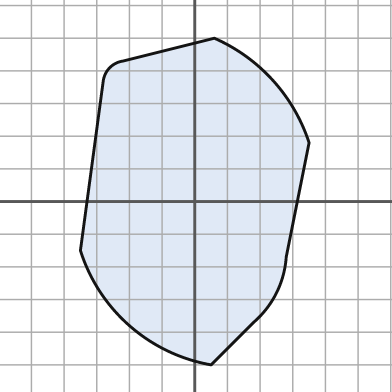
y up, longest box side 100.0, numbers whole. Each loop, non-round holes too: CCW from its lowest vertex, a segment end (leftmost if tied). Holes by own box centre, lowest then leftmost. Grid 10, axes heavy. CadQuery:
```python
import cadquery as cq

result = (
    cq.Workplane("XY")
    .moveTo(5.0, -50.0)
    .lineTo(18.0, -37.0)
    .threePointArc((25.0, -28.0), (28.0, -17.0))
    .lineTo(35.0, 18.0)
    .threePointArc((24.0, 37.0), (6.0, 50.0))
    .lineTo(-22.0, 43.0)
    .threePointArc((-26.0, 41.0), (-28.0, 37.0))
    .lineTo(-35.0, -15.0)
    .threePointArc((-20.0, -38.0), (5.0, -50.0))
    .close()
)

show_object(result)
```